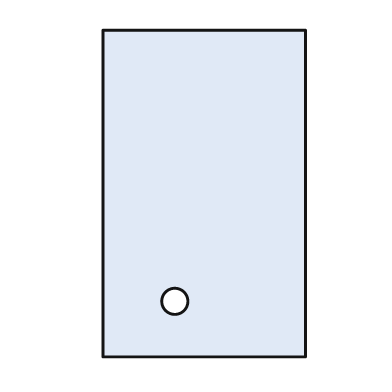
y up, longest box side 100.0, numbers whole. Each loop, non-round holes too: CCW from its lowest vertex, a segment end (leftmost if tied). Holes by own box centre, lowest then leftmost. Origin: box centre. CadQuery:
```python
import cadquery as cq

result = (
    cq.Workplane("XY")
    .moveTo(-31.0, -50.0)
    .lineTo(31.0, -50.0)
    .lineTo(31.0, 50.0)
    .lineTo(-31.0, 50.0)
    .close()
    .moveTo(-9.0, -33.0)
    .circle(4.0)
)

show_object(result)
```